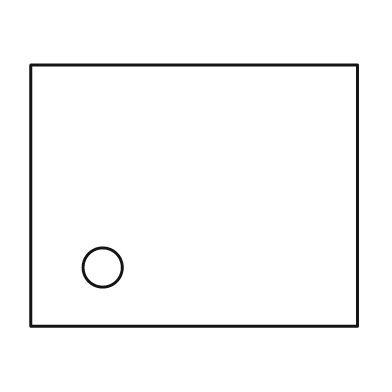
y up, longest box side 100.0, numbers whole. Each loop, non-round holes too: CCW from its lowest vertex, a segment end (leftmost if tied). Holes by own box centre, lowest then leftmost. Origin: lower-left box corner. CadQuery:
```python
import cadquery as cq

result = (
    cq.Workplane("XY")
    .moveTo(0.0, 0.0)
    .lineTo(100.0, 0.0)
    .lineTo(100.0, 80.0)
    .lineTo(0.0, 80.0)
    .close()
    .moveTo(22.0, 18.0)
    .circle(6.0)
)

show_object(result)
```